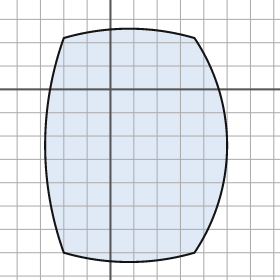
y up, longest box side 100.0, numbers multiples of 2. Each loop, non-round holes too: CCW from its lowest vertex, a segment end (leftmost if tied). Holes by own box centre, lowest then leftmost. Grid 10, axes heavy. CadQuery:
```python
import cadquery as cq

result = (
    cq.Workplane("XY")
    .moveTo(-20.0, -70.0)
    .threePointArc((8.0, -74.0), (36.0, -70.0))
    .threePointArc((50.0, -24.0), (36.0, 22.0))
    .threePointArc((8.0, 26.0), (-20.0, 22.0))
    .threePointArc((-28.0, -24.0), (-20.0, -70.0))
    .close()
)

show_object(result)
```